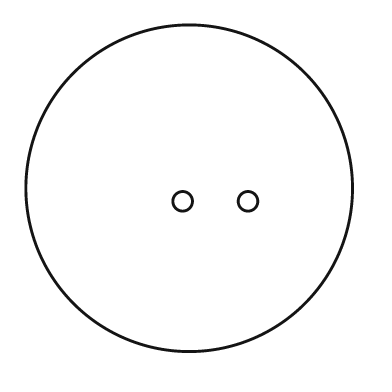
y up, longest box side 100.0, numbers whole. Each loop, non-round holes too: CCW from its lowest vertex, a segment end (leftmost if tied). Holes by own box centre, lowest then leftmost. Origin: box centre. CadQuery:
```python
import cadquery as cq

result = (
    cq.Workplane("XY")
    .moveTo(0.0, 0.0)
    .circle(50.0)
    .moveTo(-2.0, -4.0)
    .circle(3.0)
    .moveTo(18.0, -4.0)
    .circle(3.0)
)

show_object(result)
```